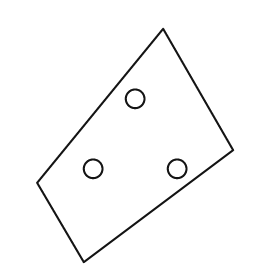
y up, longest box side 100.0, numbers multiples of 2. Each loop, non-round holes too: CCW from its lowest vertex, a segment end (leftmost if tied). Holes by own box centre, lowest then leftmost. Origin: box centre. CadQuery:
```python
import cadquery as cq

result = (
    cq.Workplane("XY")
    .moveTo(-22.0, -50.0)
    .lineTo(42.0, -2.0)
    .lineTo(12.0, 50.0)
    .lineTo(-42.0, -16.0)
    .close()
    .moveTo(-18.0, -10.0)
    .circle(4.0)
    .moveTo(18.0, -10.0)
    .circle(4.0)
    .moveTo(0.0, 20.0)
    .circle(4.0)
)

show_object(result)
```